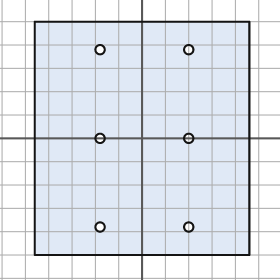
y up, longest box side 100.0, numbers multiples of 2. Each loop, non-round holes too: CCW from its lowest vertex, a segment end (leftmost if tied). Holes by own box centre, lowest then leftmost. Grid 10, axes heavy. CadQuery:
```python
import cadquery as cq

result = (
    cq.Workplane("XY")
    .moveTo(-46.0, -50.0)
    .lineTo(46.0, -50.0)
    .lineTo(46.0, 50.0)
    .lineTo(-46.0, 50.0)
    .close()
    .moveTo(-18.0, -38.0)
    .circle(2.0)
    .moveTo(20.0, -38.0)
    .circle(2.0)
    .moveTo(-18.0, 0.0)
    .circle(2.0)
    .moveTo(20.0, 0.0)
    .circle(2.0)
    .moveTo(-18.0, 38.0)
    .circle(2.0)
    .moveTo(20.0, 38.0)
    .circle(2.0)
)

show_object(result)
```